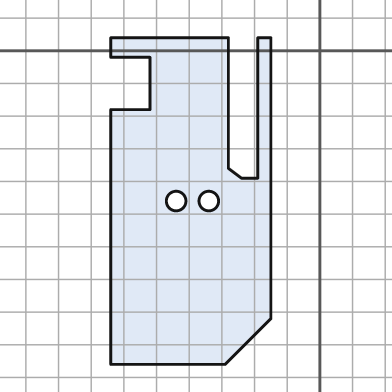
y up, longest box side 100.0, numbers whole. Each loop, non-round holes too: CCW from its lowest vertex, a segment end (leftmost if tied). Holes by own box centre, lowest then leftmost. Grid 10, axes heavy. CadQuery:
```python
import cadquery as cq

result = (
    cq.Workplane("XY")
    .moveTo(-64.0, -96.0)
    .lineTo(-29.0, -96.0)
    .lineTo(-15.0, -82.0)
    .lineTo(-15.0, 4.0)
    .lineTo(-19.0, 4.0)
    .lineTo(-19.0, -39.0)
    .lineTo(-24.0, -39.0)
    .lineTo(-28.0, -36.0)
    .lineTo(-28.0, 4.0)
    .lineTo(-64.0, 4.0)
    .lineTo(-64.0, -2.0)
    .lineTo(-52.0, -2.0)
    .lineTo(-52.0, -18.0)
    .lineTo(-64.0, -18.0)
    .close()
    .moveTo(-44.0, -46.0)
    .circle(3.0)
    .moveTo(-34.0, -46.0)
    .circle(3.0)
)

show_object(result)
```